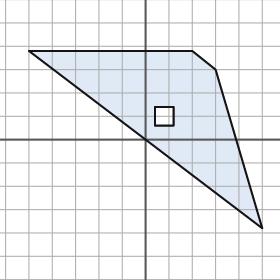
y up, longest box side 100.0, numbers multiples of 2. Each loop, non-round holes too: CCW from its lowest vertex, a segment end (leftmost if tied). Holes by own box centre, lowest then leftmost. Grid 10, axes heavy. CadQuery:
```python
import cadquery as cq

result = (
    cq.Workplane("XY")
    .moveTo(50.0, -38.0)
    .lineTo(30.0, 30.0)
    .lineTo(20.0, 38.0)
    .lineTo(-50.0, 38.0)
    .close()
    .moveTo(4.0, 6.0)
    .lineTo(12.0, 6.0)
    .lineTo(12.0, 14.0)
    .lineTo(4.0, 14.0)
    .close()
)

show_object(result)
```